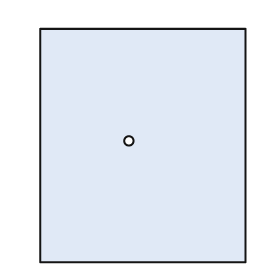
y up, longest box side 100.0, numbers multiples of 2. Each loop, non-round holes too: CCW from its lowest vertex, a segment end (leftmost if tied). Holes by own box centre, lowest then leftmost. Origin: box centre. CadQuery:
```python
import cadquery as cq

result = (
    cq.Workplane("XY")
    .moveTo(-44.0, -50.0)
    .lineTo(44.0, -50.0)
    .lineTo(44.0, 50.0)
    .lineTo(-44.0, 50.0)
    .close()
    .moveTo(-6.0, 2.0)
    .circle(2.0)
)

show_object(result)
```